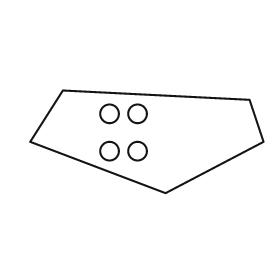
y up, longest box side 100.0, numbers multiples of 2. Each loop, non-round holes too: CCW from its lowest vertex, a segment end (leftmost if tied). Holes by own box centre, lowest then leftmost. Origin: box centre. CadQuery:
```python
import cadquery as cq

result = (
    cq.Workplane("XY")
    .moveTo(8.0, -22.0)
    .lineTo(50.0, 0.0)
    .lineTo(44.0, 18.0)
    .lineTo(-36.0, 22.0)
    .lineTo(-50.0, 0.0)
    .close()
    .moveTo(-16.0, -4.0)
    .circle(4.0)
    .moveTo(-4.0, -4.0)
    .circle(4.0)
    .moveTo(-16.0, 12.0)
    .circle(4.0)
    .moveTo(-4.0, 12.0)
    .circle(4.0)
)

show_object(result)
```